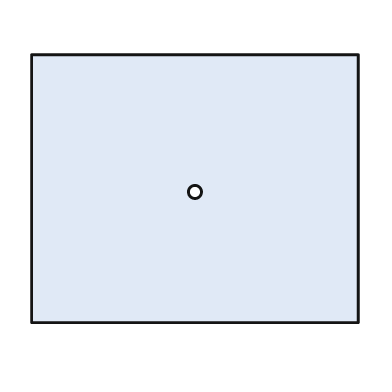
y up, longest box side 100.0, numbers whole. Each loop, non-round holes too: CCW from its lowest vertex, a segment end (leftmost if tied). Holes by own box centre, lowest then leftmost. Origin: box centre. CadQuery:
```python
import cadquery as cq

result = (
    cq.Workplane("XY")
    .moveTo(-50.0, -41.0)
    .lineTo(50.0, -41.0)
    .lineTo(50.0, 41.0)
    .lineTo(-50.0, 41.0)
    .close()
    .moveTo(0.0, -1.0)
    .circle(2.0)
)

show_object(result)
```